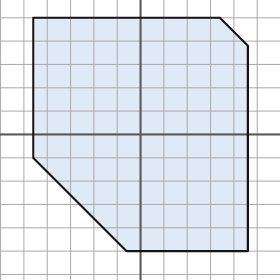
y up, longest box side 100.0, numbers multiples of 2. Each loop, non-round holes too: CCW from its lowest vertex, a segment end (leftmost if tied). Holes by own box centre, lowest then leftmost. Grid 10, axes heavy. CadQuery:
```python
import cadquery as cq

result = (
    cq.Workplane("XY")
    .moveTo(-6.0, -50.0)
    .lineTo(46.0, -50.0)
    .lineTo(46.0, 38.0)
    .lineTo(34.0, 50.0)
    .lineTo(-46.0, 50.0)
    .lineTo(-46.0, -10.0)
    .close()
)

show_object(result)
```